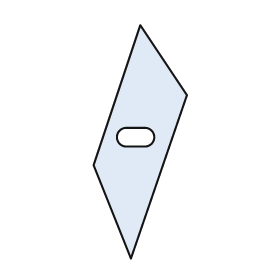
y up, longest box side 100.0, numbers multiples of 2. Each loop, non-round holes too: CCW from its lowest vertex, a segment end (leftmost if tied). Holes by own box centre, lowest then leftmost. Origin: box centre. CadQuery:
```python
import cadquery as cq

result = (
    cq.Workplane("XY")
    .moveTo(-4.0, -50.0)
    .lineTo(20.0, 20.0)
    .lineTo(0.0, 50.0)
    .lineTo(-20.0, -10.0)
    .close()
    .moveTo(-6.0, -2.0)
    .lineTo(2.0, -2.0)
    .threePointArc((6.0, 2.0), (2.0, 6.0))
    .lineTo(-6.0, 6.0)
    .threePointArc((-10.0, 2.0), (-6.0, -2.0))
    .close()
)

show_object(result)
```